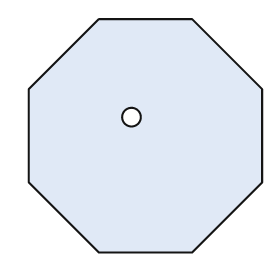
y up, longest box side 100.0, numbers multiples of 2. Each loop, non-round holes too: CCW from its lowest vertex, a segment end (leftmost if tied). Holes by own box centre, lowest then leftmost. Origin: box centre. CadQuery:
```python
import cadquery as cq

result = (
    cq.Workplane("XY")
    .moveTo(-20.0, -50.0)
    .lineTo(20.0, -50.0)
    .lineTo(50.0, -20.0)
    .lineTo(50.0, 20.0)
    .lineTo(20.0, 50.0)
    .lineTo(-20.0, 50.0)
    .lineTo(-50.0, 20.0)
    .lineTo(-50.0, -20.0)
    .close()
    .moveTo(-6.0, 8.0)
    .circle(4.0)
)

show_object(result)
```